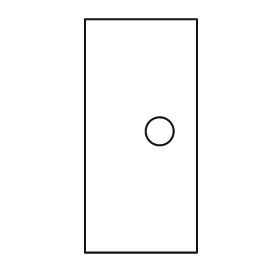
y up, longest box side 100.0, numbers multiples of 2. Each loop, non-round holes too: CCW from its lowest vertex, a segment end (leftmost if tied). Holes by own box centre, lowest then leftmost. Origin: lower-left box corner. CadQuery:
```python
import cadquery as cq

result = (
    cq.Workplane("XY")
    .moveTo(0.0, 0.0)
    .lineTo(48.0, 0.0)
    .lineTo(48.0, 100.0)
    .lineTo(0.0, 100.0)
    .close()
    .moveTo(32.0, 52.0)
    .circle(6.0)
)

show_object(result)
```